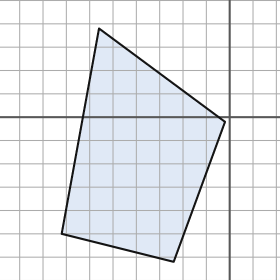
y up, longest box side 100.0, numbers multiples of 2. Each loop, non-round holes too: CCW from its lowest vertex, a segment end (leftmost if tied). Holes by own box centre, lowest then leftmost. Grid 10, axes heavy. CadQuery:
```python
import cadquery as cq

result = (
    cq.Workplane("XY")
    .moveTo(-24.0, -62.0)
    .lineTo(-2.0, -2.0)
    .lineTo(-56.0, 38.0)
    .lineTo(-72.0, -50.0)
    .close()
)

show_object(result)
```